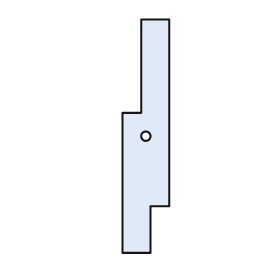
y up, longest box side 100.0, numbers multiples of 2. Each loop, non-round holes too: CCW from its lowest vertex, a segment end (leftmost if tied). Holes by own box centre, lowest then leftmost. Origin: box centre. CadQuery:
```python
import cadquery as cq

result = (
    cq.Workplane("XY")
    .moveTo(-10.0, -50.0)
    .lineTo(2.0, -50.0)
    .lineTo(2.0, -30.0)
    .lineTo(10.0, -30.0)
    .lineTo(10.0, 50.0)
    .lineTo(-2.0, 50.0)
    .lineTo(-2.0, 10.0)
    .lineTo(-10.0, 10.0)
    .close()
    .moveTo(0.0, 0.0)
    .circle(2.0)
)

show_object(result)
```